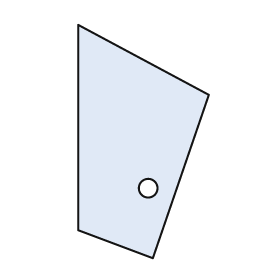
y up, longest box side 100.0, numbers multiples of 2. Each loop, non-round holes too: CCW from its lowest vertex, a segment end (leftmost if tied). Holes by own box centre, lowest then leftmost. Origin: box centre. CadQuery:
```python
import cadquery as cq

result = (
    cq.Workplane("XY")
    .moveTo(4.0, -50.0)
    .lineTo(28.0, 20.0)
    .lineTo(-28.0, 50.0)
    .lineTo(-28.0, -38.0)
    .close()
    .moveTo(2.0, -20.0)
    .circle(4.0)
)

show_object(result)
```